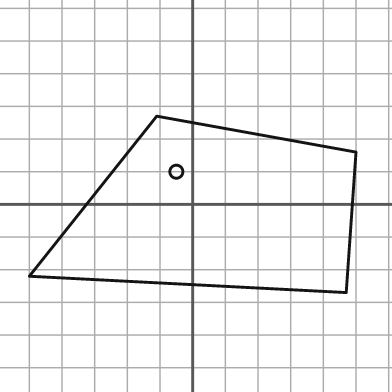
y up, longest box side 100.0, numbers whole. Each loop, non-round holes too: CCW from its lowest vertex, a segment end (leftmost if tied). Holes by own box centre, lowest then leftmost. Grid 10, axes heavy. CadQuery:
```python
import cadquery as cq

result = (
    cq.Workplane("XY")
    .moveTo(47.0, -27.0)
    .lineTo(50.0, 16.0)
    .lineTo(-11.0, 27.0)
    .lineTo(-50.0, -22.0)
    .close()
    .moveTo(-5.0, 10.0)
    .circle(2.0)
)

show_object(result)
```